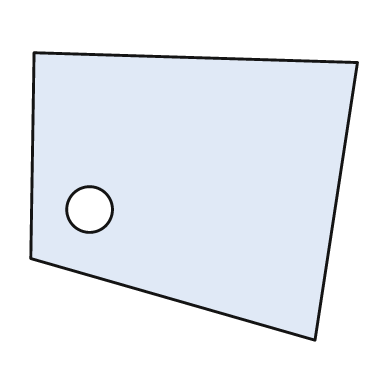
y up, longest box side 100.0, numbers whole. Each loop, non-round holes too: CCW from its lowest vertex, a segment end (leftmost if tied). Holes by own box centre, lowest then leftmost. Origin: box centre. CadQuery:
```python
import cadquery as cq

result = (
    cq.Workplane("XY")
    .moveTo(37.0, -44.0)
    .lineTo(50.0, 41.0)
    .lineTo(-49.0, 44.0)
    .lineTo(-50.0, -19.0)
    .close()
    .moveTo(-32.0, -4.0)
    .circle(7.0)
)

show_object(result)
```